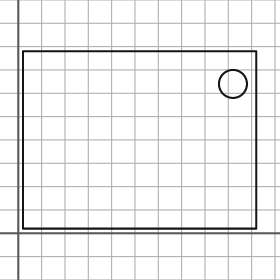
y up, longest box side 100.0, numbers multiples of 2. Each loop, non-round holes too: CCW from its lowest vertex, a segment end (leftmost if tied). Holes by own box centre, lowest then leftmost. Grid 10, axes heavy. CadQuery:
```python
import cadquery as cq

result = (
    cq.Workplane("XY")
    .moveTo(2.0, 2.0)
    .lineTo(102.0, 2.0)
    .lineTo(102.0, 78.0)
    .lineTo(2.0, 78.0)
    .close()
    .moveTo(92.0, 64.0)
    .circle(6.0)
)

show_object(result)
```